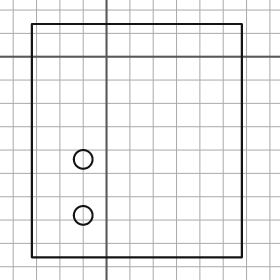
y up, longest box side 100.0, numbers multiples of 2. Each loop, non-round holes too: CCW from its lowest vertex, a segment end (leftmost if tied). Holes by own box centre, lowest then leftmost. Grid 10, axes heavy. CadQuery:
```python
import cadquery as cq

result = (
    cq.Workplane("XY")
    .moveTo(-32.0, -86.0)
    .lineTo(58.0, -86.0)
    .lineTo(58.0, 14.0)
    .lineTo(-32.0, 14.0)
    .close()
    .moveTo(-10.0, -68.0)
    .circle(4.0)
    .moveTo(-10.0, -44.0)
    .circle(4.0)
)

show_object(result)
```